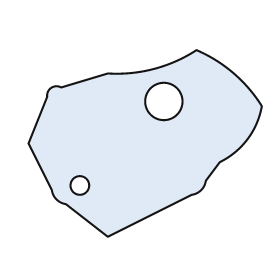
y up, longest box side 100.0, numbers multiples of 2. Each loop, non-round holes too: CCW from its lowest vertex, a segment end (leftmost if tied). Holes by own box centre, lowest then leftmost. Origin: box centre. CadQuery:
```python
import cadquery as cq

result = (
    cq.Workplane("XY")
    .moveTo(-16.0, -40.0)
    .lineTo(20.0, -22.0)
    .threePointArc((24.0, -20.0), (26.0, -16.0))
    .lineTo(32.0, -8.0)
    .threePointArc((44.0, 2.0), (50.0, 16.0))
    .threePointArc((38.0, 30.0), (22.0, 40.0))
    .threePointArc((4.0, 32.0), (-16.0, 30.0))
    .lineTo(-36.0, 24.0)
    .threePointArc((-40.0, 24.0), (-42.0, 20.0))
    .lineTo(-50.0, 0.0)
    .lineTo(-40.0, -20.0)
    .threePointArc((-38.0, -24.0), (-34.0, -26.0))
    .close()
    .moveTo(-28.0, -18.0)
    .circle(4.0)
    .moveTo(8.0, 18.0)
    .circle(8.0)
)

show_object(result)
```